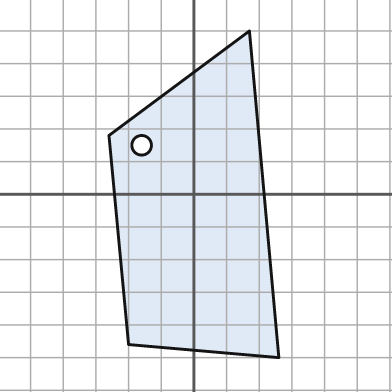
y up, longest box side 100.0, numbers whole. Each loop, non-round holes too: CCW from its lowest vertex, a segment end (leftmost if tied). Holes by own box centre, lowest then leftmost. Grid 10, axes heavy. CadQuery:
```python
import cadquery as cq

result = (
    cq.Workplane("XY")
    .moveTo(26.0, -50.0)
    .lineTo(17.0, 50.0)
    .lineTo(-26.0, 18.0)
    .lineTo(-20.0, -46.0)
    .close()
    .moveTo(-16.0, 15.0)
    .circle(3.0)
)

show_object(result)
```